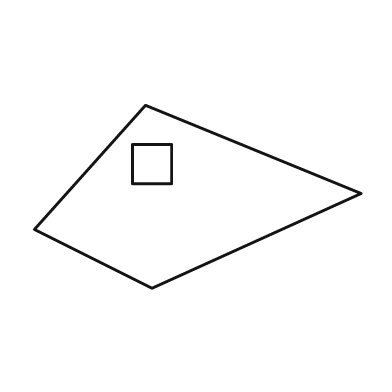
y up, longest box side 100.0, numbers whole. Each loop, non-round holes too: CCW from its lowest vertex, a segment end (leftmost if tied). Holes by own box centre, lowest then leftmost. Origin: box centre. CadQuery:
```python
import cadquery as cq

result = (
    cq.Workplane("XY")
    .moveTo(-14.0, -28.0)
    .lineTo(50.0, 1.0)
    .lineTo(-16.0, 28.0)
    .lineTo(-50.0, -10.0)
    .close()
    .moveTo(-20.0, 4.0)
    .lineTo(-8.0, 4.0)
    .lineTo(-8.0, 16.0)
    .lineTo(-20.0, 16.0)
    .close()
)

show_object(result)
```